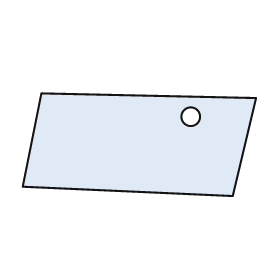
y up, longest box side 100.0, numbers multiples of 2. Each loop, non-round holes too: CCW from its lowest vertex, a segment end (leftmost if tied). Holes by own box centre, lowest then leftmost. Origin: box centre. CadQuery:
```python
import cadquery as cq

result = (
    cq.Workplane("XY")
    .moveTo(40.0, -22.0)
    .lineTo(50.0, 20.0)
    .lineTo(-42.0, 22.0)
    .lineTo(-50.0, -18.0)
    .close()
    .moveTo(22.0, 12.0)
    .circle(4.0)
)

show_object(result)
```